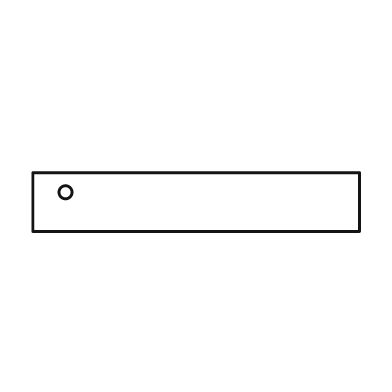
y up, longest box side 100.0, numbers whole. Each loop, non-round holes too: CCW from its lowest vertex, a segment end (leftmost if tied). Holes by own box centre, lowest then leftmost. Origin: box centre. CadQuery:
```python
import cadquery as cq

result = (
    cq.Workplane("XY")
    .moveTo(-50.0, -9.0)
    .lineTo(50.0, -9.0)
    .lineTo(50.0, 9.0)
    .lineTo(-50.0, 9.0)
    .close()
    .moveTo(-40.0, 3.0)
    .circle(2.0)
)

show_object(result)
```